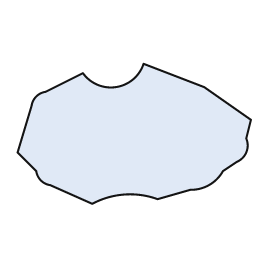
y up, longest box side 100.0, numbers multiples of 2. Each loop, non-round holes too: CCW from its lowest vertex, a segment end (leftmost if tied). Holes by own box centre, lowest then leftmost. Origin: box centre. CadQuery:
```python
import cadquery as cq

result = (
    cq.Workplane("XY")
    .moveTo(-18.0, -30.0)
    .threePointArc((-4.0, -26.0), (10.0, -28.0))
    .lineTo(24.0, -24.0)
    .threePointArc((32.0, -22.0), (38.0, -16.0))
    .lineTo(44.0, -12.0)
    .threePointArc((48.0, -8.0), (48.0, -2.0))
    .lineTo(50.0, 6.0)
    .lineTo(30.0, 20.0)
    .lineTo(4.0, 30.0)
    .threePointArc((-8.0, 20.0), (-22.0, 26.0))
    .lineTo(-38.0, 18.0)
    .threePointArc((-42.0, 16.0), (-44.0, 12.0))
    .lineTo(-50.0, -8.0)
    .lineTo(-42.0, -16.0)
    .threePointArc((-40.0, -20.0), (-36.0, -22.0))
    .close()
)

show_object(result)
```